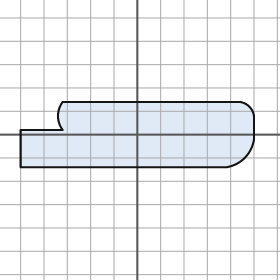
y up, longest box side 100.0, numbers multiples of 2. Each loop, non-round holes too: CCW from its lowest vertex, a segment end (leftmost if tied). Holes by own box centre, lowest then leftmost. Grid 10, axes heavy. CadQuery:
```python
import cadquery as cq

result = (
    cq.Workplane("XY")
    .moveTo(-50.0, -14.0)
    .lineTo(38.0, -14.0)
    .threePointArc((46.0, -10.0), (50.0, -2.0))
    .lineTo(50.0, 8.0)
    .threePointArc((48.0, 12.0), (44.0, 14.0))
    .lineTo(-32.0, 14.0)
    .threePointArc((-34.0, 8.0), (-32.0, 2.0))
    .lineTo(-50.0, 2.0)
    .close()
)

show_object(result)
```